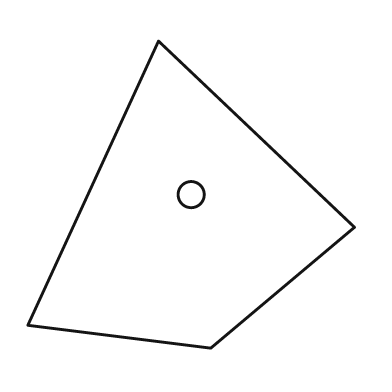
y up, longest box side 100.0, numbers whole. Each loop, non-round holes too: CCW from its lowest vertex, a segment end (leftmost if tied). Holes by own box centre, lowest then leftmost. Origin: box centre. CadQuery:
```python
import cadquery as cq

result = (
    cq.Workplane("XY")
    .moveTo(6.0, -47.0)
    .lineTo(50.0, -10.0)
    .lineTo(-10.0, 47.0)
    .lineTo(-50.0, -40.0)
    .close()
    .moveTo(0.0, 0.0)
    .circle(4.0)
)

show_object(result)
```